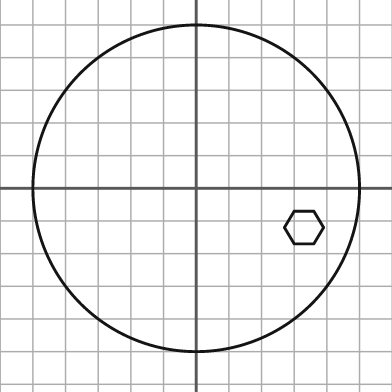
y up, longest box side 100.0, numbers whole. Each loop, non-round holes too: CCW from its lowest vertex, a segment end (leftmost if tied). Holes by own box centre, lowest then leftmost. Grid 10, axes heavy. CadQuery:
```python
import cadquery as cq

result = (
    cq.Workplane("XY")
    .moveTo(0.0, 0.0)
    .circle(50.0)
    .moveTo(30.0, -17.0)
    .lineTo(36.0, -17.0)
    .lineTo(39.0, -12.0)
    .lineTo(36.0, -7.0)
    .lineTo(30.0, -7.0)
    .lineTo(27.0, -12.0)
    .close()
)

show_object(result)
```